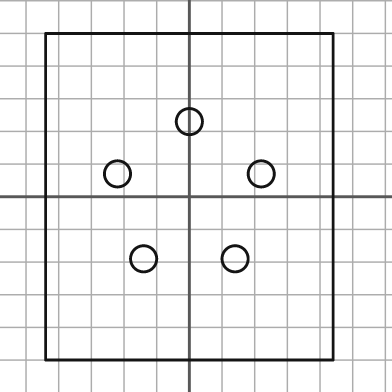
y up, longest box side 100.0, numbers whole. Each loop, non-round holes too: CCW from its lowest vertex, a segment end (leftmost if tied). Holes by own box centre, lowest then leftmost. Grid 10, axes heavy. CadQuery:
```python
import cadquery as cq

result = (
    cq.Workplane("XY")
    .moveTo(-44.0, -50.0)
    .lineTo(44.0, -50.0)
    .lineTo(44.0, 50.0)
    .lineTo(-44.0, 50.0)
    .close()
    .moveTo(-14.0, -19.0)
    .circle(4.0)
    .moveTo(14.0, -19.0)
    .circle(4.0)
    .moveTo(-22.0, 7.0)
    .circle(4.0)
    .moveTo(22.0, 7.0)
    .circle(4.0)
    .moveTo(0.0, 23.0)
    .circle(4.0)
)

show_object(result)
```